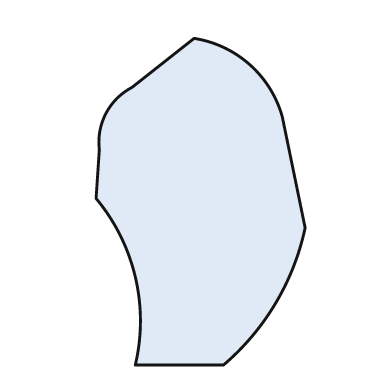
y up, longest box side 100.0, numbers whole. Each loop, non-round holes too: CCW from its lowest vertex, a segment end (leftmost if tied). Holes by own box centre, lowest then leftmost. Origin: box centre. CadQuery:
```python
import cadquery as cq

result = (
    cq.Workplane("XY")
    .moveTo(-20.0, -50.0)
    .lineTo(7.0, -50.0)
    .threePointArc((23.0, -31.0), (32.0, -8.0))
    .lineTo(25.0, 26.0)
    .threePointArc((15.0, 42.0), (-2.0, 50.0))
    .lineTo(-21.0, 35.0)
    .threePointArc((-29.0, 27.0), (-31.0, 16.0))
    .lineTo(-32.0, 1.0)
    .threePointArc((-20.0, -23.0), (-20.0, -50.0))
    .close()
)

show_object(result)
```